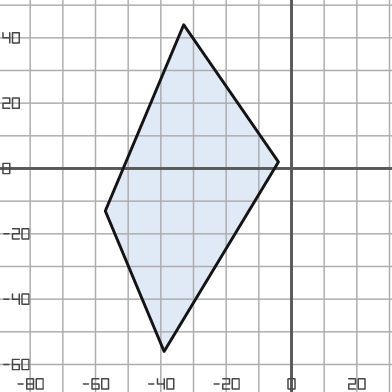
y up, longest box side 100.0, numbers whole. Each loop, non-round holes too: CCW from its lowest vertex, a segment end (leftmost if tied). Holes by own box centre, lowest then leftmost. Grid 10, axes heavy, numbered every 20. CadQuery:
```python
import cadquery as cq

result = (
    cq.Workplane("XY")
    .moveTo(-39.0, -56.0)
    .lineTo(-4.0, 2.0)
    .lineTo(-33.0, 44.0)
    .lineTo(-57.0, -13.0)
    .close()
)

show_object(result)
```